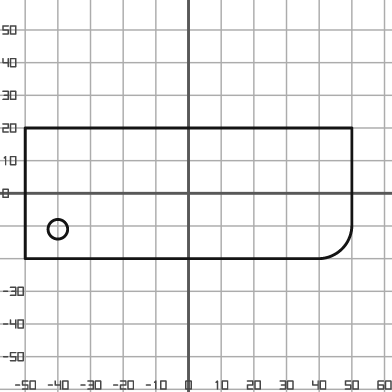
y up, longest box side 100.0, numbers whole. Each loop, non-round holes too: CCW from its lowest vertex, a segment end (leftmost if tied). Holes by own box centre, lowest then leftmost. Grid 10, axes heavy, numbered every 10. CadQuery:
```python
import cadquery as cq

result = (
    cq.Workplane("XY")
    .moveTo(-50.0, -20.0)
    .lineTo(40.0, -20.0)
    .threePointArc((47.0, -17.0), (50.0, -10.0))
    .lineTo(50.0, 20.0)
    .lineTo(-50.0, 20.0)
    .close()
    .moveTo(-40.0, -11.0)
    .circle(3.0)
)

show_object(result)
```